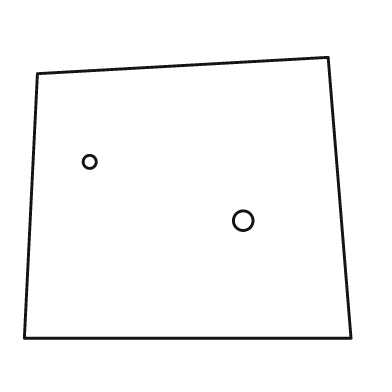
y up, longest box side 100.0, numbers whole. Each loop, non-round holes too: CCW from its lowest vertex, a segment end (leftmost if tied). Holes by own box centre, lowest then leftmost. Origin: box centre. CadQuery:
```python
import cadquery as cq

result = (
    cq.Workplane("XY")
    .moveTo(-50.0, -43.0)
    .lineTo(50.0, -43.0)
    .lineTo(43.0, 43.0)
    .lineTo(-46.0, 38.0)
    .close()
    .moveTo(17.0, -7.0)
    .circle(3.0)
    .moveTo(-30.0, 11.0)
    .circle(2.0)
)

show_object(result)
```